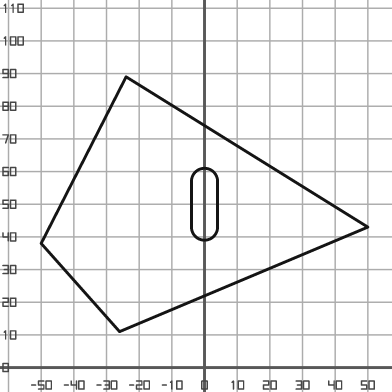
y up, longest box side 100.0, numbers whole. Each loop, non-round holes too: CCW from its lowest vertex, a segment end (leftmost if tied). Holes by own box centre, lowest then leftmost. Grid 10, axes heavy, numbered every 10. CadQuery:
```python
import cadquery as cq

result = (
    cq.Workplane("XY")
    .moveTo(-26.0, 11.0)
    .lineTo(50.0, 43.0)
    .lineTo(-24.0, 89.0)
    .lineTo(-50.0, 38.0)
    .close()
    .moveTo(-4.0, 43.0)
    .threePointArc((0.0, 39.0), (4.0, 43.0))
    .lineTo(4.0, 57.0)
    .threePointArc((0.0, 61.0), (-4.0, 57.0))
    .close()
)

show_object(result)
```